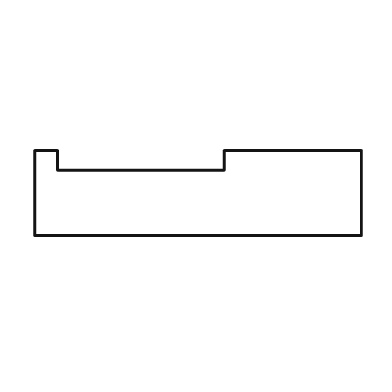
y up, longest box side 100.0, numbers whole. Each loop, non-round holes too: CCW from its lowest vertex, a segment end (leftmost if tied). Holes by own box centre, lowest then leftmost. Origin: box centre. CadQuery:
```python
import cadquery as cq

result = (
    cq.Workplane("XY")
    .moveTo(-50.0, -13.0)
    .lineTo(50.0, -13.0)
    .lineTo(50.0, 13.0)
    .lineTo(8.0, 13.0)
    .lineTo(8.0, 7.0)
    .lineTo(-43.0, 7.0)
    .lineTo(-43.0, 13.0)
    .lineTo(-50.0, 13.0)
    .close()
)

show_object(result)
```